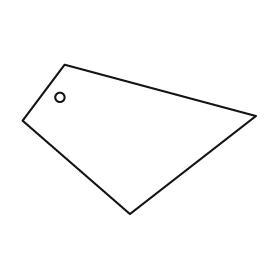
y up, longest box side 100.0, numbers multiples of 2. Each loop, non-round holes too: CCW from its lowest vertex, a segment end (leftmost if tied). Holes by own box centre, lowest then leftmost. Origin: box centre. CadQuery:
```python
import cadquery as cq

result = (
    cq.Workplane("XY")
    .moveTo(-4.0, -32.0)
    .lineTo(50.0, 10.0)
    .lineTo(-32.0, 32.0)
    .lineTo(-50.0, 8.0)
    .close()
    .moveTo(-34.0, 18.0)
    .circle(2.0)
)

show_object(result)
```